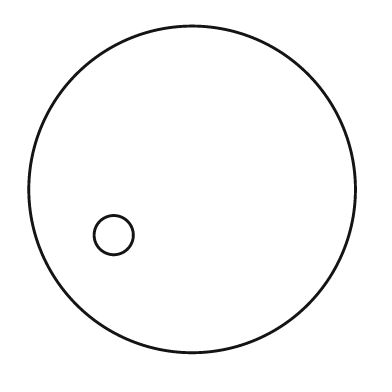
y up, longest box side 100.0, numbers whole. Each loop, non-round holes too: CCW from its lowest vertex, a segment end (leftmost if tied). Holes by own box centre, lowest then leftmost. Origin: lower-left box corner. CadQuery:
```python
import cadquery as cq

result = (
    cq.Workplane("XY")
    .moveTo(50.0, 50.0)
    .circle(50.0)
    .moveTo(26.0, 36.0)
    .circle(6.0)
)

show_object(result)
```